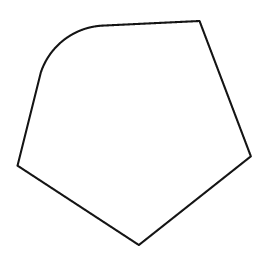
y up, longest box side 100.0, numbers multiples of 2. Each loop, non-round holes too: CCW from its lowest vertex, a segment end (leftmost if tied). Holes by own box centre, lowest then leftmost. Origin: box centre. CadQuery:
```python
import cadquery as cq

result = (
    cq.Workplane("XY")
    .moveTo(2.0, -48.0)
    .lineTo(50.0, -10.0)
    .lineTo(28.0, 48.0)
    .lineTo(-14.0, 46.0)
    .threePointArc((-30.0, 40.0), (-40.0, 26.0))
    .lineTo(-50.0, -14.0)
    .close()
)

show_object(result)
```